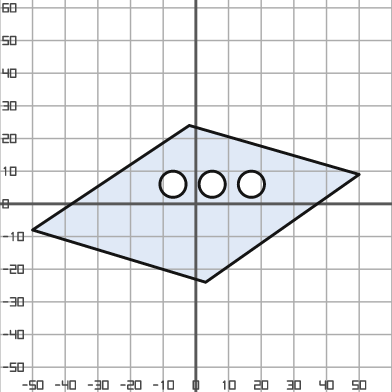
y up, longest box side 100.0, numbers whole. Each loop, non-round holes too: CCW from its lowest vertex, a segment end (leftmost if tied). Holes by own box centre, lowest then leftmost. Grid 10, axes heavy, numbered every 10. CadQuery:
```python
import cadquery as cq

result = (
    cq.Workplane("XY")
    .moveTo(3.0, -24.0)
    .lineTo(50.0, 9.0)
    .lineTo(-2.0, 24.0)
    .lineTo(-50.0, -8.0)
    .close()
    .moveTo(-7.0, 6.0)
    .circle(4.0)
    .moveTo(5.0, 6.0)
    .circle(4.0)
    .moveTo(17.0, 6.0)
    .circle(4.0)
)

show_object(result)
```